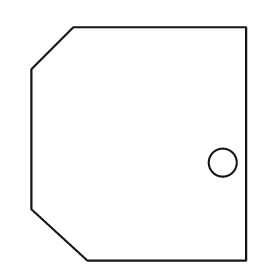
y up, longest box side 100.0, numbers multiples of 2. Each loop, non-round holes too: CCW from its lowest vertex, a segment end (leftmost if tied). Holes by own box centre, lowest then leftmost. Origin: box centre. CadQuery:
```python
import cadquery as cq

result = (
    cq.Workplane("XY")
    .moveTo(-22.0, -50.0)
    .lineTo(46.0, -50.0)
    .lineTo(46.0, 50.0)
    .lineTo(-28.0, 50.0)
    .lineTo(-46.0, 32.0)
    .lineTo(-46.0, -28.0)
    .close()
    .moveTo(36.0, -8.0)
    .circle(6.0)
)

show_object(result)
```